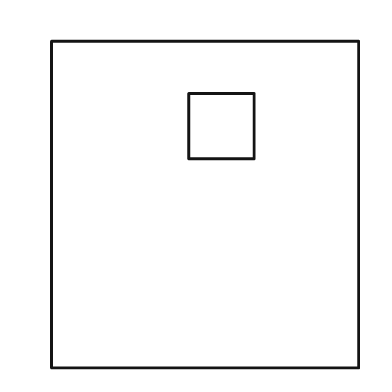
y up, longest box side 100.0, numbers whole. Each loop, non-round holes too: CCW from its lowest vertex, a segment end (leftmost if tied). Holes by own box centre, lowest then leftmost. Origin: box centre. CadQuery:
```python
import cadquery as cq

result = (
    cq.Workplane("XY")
    .moveTo(-47.0, -50.0)
    .lineTo(47.0, -50.0)
    .lineTo(47.0, 50.0)
    .lineTo(-47.0, 50.0)
    .close()
    .moveTo(-5.0, 14.0)
    .lineTo(15.0, 14.0)
    .lineTo(15.0, 34.0)
    .lineTo(-5.0, 34.0)
    .close()
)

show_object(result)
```